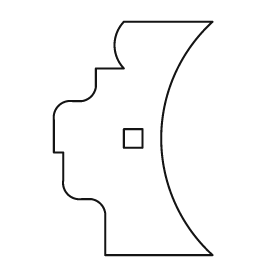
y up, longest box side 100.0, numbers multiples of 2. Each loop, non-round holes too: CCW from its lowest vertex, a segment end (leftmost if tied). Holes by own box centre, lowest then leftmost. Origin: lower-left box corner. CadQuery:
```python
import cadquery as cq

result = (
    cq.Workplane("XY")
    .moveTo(22.0, 0.0)
    .lineTo(68.0, 0.0)
    .threePointArc((46.0, 50.0), (68.0, 100.0))
    .lineTo(30.0, 100.0)
    .threePointArc((26.0, 90.0), (30.0, 80.0))
    .lineTo(18.0, 80.0)
    .lineTo(18.0, 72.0)
    .threePointArc((16.0, 68.0), (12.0, 66.0))
    .lineTo(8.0, 66.0)
    .threePointArc((2.0, 64.0), (0.0, 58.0))
    .lineTo(0.0, 44.0)
    .lineTo(4.0, 44.0)
    .lineTo(4.0, 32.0)
    .threePointArc((6.0, 26.0), (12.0, 24.0))
    .lineTo(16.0, 24.0)
    .threePointArc((20.0, 22.0), (22.0, 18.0))
    .close()
    .moveTo(30.0, 46.0)
    .lineTo(38.0, 46.0)
    .lineTo(38.0, 54.0)
    .lineTo(30.0, 54.0)
    .close()
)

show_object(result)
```